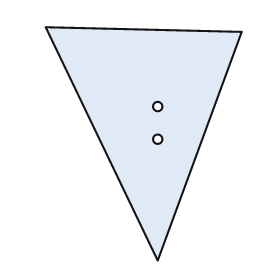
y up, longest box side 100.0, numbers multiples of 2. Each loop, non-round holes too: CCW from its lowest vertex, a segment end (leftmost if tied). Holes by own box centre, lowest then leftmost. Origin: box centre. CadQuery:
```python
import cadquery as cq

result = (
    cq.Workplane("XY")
    .moveTo(6.0, -50.0)
    .lineTo(42.0, 48.0)
    .lineTo(-42.0, 50.0)
    .close()
    .moveTo(6.0, 2.0)
    .circle(2.0)
    .moveTo(6.0, 16.0)
    .circle(2.0)
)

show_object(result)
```